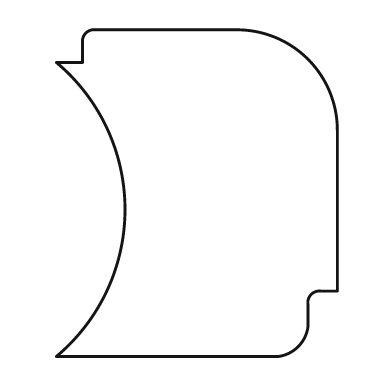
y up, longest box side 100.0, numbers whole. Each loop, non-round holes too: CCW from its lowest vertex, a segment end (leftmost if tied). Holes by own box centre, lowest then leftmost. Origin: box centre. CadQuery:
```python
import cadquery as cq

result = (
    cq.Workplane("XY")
    .moveTo(-43.0, -50.0)
    .lineTo(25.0, -50.0)
    .threePointArc((31.0, -47.0), (34.0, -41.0))
    .lineTo(34.0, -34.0)
    .threePointArc((35.0, -31.0), (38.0, -30.0))
    .lineTo(43.0, -30.0)
    .lineTo(43.0, 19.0)
    .threePointArc((34.0, 41.0), (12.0, 50.0))
    .lineTo(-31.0, 50.0)
    .threePointArc((-34.0, 49.0), (-35.0, 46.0))
    .lineTo(-35.0, 40.0)
    .lineTo(-43.0, 40.0)
    .threePointArc((-22.0, -5.0), (-43.0, -50.0))
    .close()
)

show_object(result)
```